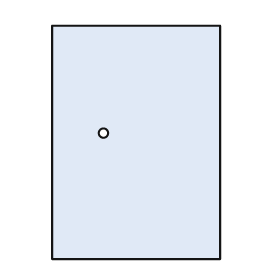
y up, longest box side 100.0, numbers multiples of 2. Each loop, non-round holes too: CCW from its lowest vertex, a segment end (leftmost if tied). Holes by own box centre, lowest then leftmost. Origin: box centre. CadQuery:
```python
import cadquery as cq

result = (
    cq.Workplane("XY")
    .moveTo(-36.0, -50.0)
    .lineTo(36.0, -50.0)
    .lineTo(36.0, 50.0)
    .lineTo(-36.0, 50.0)
    .close()
    .moveTo(-14.0, 4.0)
    .circle(2.0)
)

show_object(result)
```